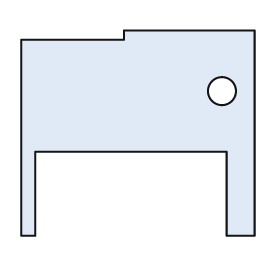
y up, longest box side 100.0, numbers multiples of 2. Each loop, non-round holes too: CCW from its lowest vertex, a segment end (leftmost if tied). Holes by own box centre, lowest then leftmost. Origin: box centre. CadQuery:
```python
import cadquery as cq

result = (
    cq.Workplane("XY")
    .moveTo(-50.0, -44.0)
    .lineTo(-44.0, -44.0)
    .lineTo(-44.0, -8.0)
    .lineTo(38.0, -8.0)
    .lineTo(38.0, -44.0)
    .lineTo(50.0, -44.0)
    .lineTo(50.0, 44.0)
    .lineTo(-6.0, 44.0)
    .lineTo(-6.0, 40.0)
    .lineTo(-50.0, 40.0)
    .close()
    .moveTo(36.0, 18.0)
    .circle(6.0)
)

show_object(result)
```